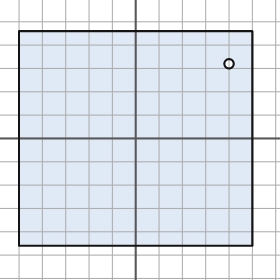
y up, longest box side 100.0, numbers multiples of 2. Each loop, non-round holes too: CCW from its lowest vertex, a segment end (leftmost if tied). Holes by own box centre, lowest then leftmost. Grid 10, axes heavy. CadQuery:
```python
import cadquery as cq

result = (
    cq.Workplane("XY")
    .moveTo(-50.0, -46.0)
    .lineTo(50.0, -46.0)
    .lineTo(50.0, 46.0)
    .lineTo(-50.0, 46.0)
    .close()
    .moveTo(40.0, 32.0)
    .circle(2.0)
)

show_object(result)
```